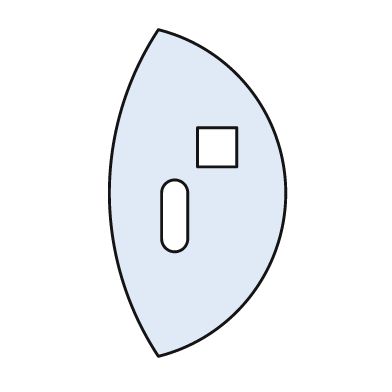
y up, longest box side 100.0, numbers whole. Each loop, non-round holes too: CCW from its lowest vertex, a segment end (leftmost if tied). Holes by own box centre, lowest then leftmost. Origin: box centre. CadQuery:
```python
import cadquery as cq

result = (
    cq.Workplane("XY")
    .moveTo(-12.0, -50.0)
    .threePointArc((27.0, 0.0), (-12.0, 50.0))
    .threePointArc((-27.0, 0.0), (-12.0, -50.0))
    .close()
    .moveTo(-11.0, -14.0)
    .threePointArc((-7.0, -18.0), (-3.0, -14.0))
    .lineTo(-3.0, 0.0)
    .threePointArc((-7.0, 4.0), (-11.0, 0.0))
    .close()
    .moveTo(0.0, 8.0)
    .lineTo(12.0, 8.0)
    .lineTo(12.0, 20.0)
    .lineTo(0.0, 20.0)
    .close()
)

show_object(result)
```